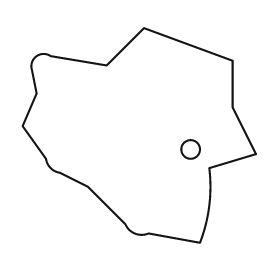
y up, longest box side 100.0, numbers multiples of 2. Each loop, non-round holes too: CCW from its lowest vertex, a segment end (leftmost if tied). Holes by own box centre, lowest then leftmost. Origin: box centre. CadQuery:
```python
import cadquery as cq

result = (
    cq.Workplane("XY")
    .moveTo(26.0, -46.0)
    .threePointArc((30.0, -30.0), (30.0, -14.0))
    .lineTo(50.0, -8.0)
    .lineTo(40.0, 12.0)
    .lineTo(40.0, 32.0)
    .lineTo(2.0, 46.0)
    .lineTo(-14.0, 30.0)
    .lineTo(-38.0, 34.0)
    .threePointArc((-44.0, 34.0), (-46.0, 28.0))
    .lineTo(-44.0, 18.0)
    .lineTo(-50.0, 4.0)
    .lineTo(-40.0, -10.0)
    .threePointArc((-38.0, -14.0), (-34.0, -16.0))
    .lineTo(-22.0, -22.0)
    .lineTo(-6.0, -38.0)
    .threePointArc((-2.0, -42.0), (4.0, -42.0))
    .close()
    .moveTo(22.0, -6.0)
    .circle(4.0)
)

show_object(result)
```